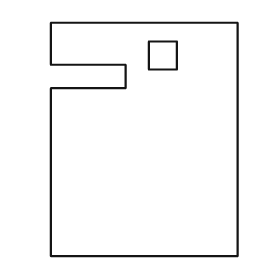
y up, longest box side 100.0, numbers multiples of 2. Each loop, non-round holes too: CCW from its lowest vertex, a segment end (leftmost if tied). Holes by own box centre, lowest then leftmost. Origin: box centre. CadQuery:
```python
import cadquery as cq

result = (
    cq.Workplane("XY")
    .moveTo(-40.0, -50.0)
    .lineTo(40.0, -50.0)
    .lineTo(40.0, 50.0)
    .lineTo(-40.0, 50.0)
    .lineTo(-40.0, 32.0)
    .lineTo(-8.0, 32.0)
    .lineTo(-8.0, 22.0)
    .lineTo(-40.0, 22.0)
    .close()
    .moveTo(2.0, 30.0)
    .lineTo(14.0, 30.0)
    .lineTo(14.0, 42.0)
    .lineTo(2.0, 42.0)
    .close()
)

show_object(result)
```